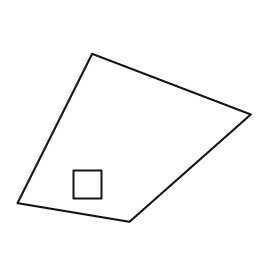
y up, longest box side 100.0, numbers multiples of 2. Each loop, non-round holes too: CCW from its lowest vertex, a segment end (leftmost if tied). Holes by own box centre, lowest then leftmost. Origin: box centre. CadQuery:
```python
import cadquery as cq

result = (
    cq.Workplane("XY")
    .moveTo(-2.0, -36.0)
    .lineTo(50.0, 10.0)
    .lineTo(-18.0, 36.0)
    .lineTo(-50.0, -28.0)
    .close()
    .moveTo(-26.0, -26.0)
    .lineTo(-14.0, -26.0)
    .lineTo(-14.0, -14.0)
    .lineTo(-26.0, -14.0)
    .close()
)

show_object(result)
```